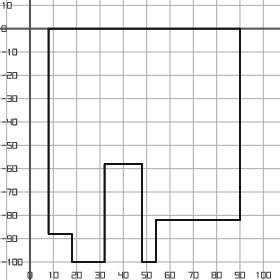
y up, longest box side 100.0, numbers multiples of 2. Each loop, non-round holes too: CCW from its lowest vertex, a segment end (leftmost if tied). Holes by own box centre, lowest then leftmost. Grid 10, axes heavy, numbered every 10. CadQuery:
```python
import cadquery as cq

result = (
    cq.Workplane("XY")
    .moveTo(18.0, -100.0)
    .lineTo(32.0, -100.0)
    .lineTo(32.0, -58.0)
    .lineTo(48.0, -58.0)
    .lineTo(48.0, -100.0)
    .lineTo(54.0, -100.0)
    .lineTo(54.0, -82.0)
    .lineTo(90.0, -82.0)
    .lineTo(90.0, 0.0)
    .lineTo(8.0, 0.0)
    .lineTo(8.0, -88.0)
    .lineTo(18.0, -88.0)
    .close()
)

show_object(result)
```